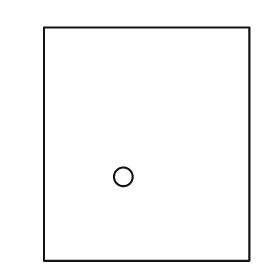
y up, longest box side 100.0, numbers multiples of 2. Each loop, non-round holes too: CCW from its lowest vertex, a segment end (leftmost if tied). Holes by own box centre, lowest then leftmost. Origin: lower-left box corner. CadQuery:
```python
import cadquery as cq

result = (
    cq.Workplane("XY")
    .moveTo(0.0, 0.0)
    .lineTo(88.0, 0.0)
    .lineTo(88.0, 100.0)
    .lineTo(0.0, 100.0)
    .close()
    .moveTo(34.0, 36.0)
    .circle(4.0)
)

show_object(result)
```